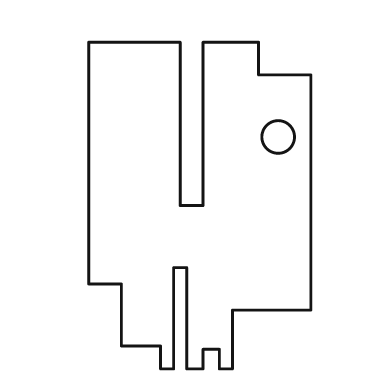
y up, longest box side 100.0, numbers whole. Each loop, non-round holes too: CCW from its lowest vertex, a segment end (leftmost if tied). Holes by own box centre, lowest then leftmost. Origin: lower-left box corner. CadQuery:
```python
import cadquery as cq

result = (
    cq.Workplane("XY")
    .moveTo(22.0, 0.0)
    .lineTo(26.0, 0.0)
    .lineTo(26.0, 31.0)
    .lineTo(30.0, 31.0)
    .lineTo(30.0, 0.0)
    .lineTo(35.0, 0.0)
    .lineTo(35.0, 6.0)
    .lineTo(40.0, 6.0)
    .lineTo(40.0, 0.0)
    .lineTo(44.0, 0.0)
    .lineTo(44.0, 18.0)
    .lineTo(68.0, 18.0)
    .lineTo(68.0, 90.0)
    .lineTo(52.0, 90.0)
    .lineTo(52.0, 100.0)
    .lineTo(35.0, 100.0)
    .lineTo(35.0, 50.0)
    .lineTo(28.0, 50.0)
    .lineTo(28.0, 100.0)
    .lineTo(0.0, 100.0)
    .lineTo(0.0, 26.0)
    .lineTo(10.0, 26.0)
    .lineTo(10.0, 7.0)
    .lineTo(22.0, 7.0)
    .close()
    .moveTo(58.0, 71.0)
    .circle(5.0)
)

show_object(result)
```